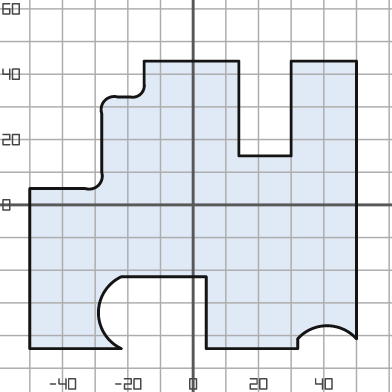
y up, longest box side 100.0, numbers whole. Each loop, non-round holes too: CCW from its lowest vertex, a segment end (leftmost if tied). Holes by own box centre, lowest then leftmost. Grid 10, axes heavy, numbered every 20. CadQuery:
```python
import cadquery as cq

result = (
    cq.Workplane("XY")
    .moveTo(-50.0, -44.0)
    .lineTo(-22.0, -44.0)
    .threePointArc((-29.0, -33.0), (-22.0, -22.0))
    .lineTo(4.0, -22.0)
    .lineTo(4.0, -44.0)
    .lineTo(32.0, -44.0)
    .lineTo(32.0, -41.0)
    .threePointArc((41.0, -37.0), (50.0, -41.0))
    .lineTo(50.0, 44.0)
    .lineTo(30.0, 44.0)
    .lineTo(30.0, 15.0)
    .lineTo(14.0, 15.0)
    .lineTo(14.0, 44.0)
    .lineTo(-15.0, 44.0)
    .lineTo(-15.0, 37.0)
    .threePointArc((-16.0, 34.0), (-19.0, 33.0))
    .lineTo(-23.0, 33.0)
    .threePointArc((-27.0, 32.0), (-28.0, 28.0))
    .lineTo(-28.0, 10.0)
    .threePointArc((-29.0, 6.0), (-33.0, 5.0))
    .lineTo(-50.0, 5.0)
    .close()
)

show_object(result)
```